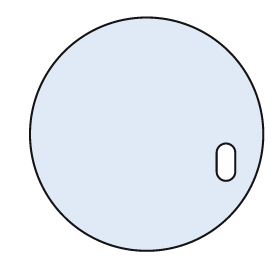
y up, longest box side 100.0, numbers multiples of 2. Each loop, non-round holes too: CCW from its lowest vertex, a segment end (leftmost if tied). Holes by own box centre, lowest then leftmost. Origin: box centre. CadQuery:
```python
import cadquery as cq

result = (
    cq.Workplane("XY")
    .moveTo(0.0, 0.0)
    .circle(50.0)
    .moveTo(30.0, -16.0)
    .threePointArc((34.0, -20.0), (38.0, -16.0))
    .lineTo(38.0, -8.0)
    .threePointArc((34.0, -4.0), (30.0, -8.0))
    .close()
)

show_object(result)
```